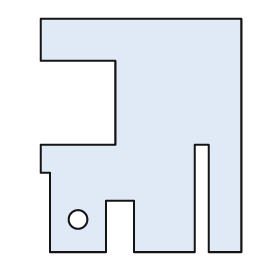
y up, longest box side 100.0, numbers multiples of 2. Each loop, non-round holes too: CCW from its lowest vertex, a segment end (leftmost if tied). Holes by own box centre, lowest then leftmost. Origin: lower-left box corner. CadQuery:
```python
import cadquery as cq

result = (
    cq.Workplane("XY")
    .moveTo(4.0, 0.0)
    .lineTo(28.0, 0.0)
    .lineTo(28.0, 22.0)
    .lineTo(40.0, 22.0)
    .lineTo(40.0, 0.0)
    .lineTo(66.0, 0.0)
    .lineTo(66.0, 46.0)
    .lineTo(72.0, 46.0)
    .lineTo(72.0, 0.0)
    .lineTo(86.0, 0.0)
    .lineTo(86.0, 100.0)
    .lineTo(0.0, 100.0)
    .lineTo(0.0, 82.0)
    .lineTo(32.0, 82.0)
    .lineTo(32.0, 46.0)
    .lineTo(0.0, 46.0)
    .lineTo(0.0, 34.0)
    .lineTo(4.0, 34.0)
    .close()
    .moveTo(16.0, 14.0)
    .circle(4.0)
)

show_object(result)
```